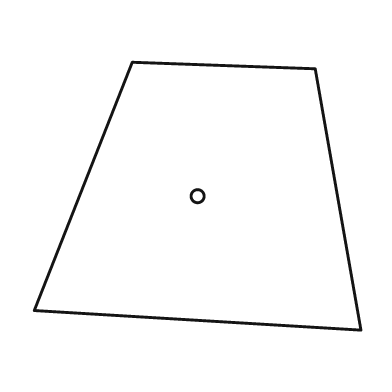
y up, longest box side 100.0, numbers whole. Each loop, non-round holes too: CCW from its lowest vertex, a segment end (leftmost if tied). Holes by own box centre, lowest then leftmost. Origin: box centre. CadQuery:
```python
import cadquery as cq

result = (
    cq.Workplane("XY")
    .moveTo(50.0, -41.0)
    .lineTo(36.0, 39.0)
    .lineTo(-20.0, 41.0)
    .lineTo(-50.0, -35.0)
    .close()
    .moveTo(0.0, 0.0)
    .circle(2.0)
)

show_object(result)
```